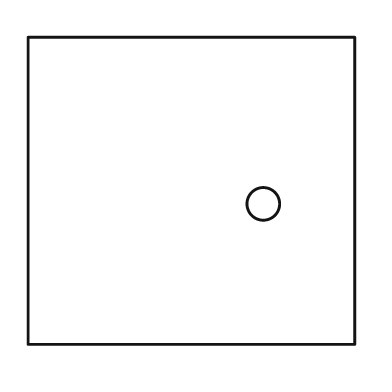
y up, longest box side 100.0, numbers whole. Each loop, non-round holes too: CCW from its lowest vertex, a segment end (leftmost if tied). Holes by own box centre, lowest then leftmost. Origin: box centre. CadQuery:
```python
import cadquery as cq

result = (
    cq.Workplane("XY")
    .moveTo(-50.0, -47.0)
    .lineTo(50.0, -47.0)
    .lineTo(50.0, 47.0)
    .lineTo(-50.0, 47.0)
    .close()
    .moveTo(22.0, -4.0)
    .circle(5.0)
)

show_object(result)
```